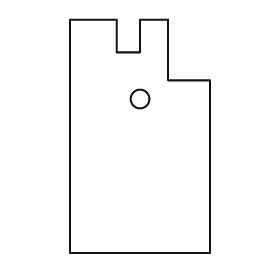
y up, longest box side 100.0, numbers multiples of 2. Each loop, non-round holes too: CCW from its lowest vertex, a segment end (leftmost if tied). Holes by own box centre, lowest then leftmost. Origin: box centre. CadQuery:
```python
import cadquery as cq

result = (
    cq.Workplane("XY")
    .moveTo(-30.0, -50.0)
    .lineTo(30.0, -50.0)
    .lineTo(30.0, 24.0)
    .lineTo(12.0, 24.0)
    .lineTo(12.0, 50.0)
    .lineTo(0.0, 50.0)
    .lineTo(0.0, 36.0)
    .lineTo(-10.0, 36.0)
    .lineTo(-10.0, 50.0)
    .lineTo(-30.0, 50.0)
    .close()
    .moveTo(0.0, 16.0)
    .circle(4.0)
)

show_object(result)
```